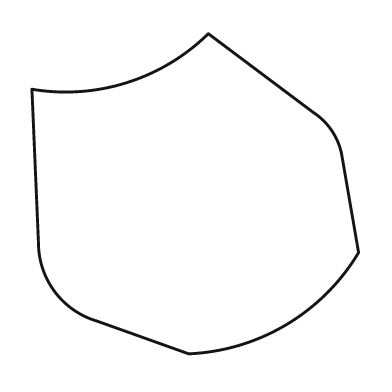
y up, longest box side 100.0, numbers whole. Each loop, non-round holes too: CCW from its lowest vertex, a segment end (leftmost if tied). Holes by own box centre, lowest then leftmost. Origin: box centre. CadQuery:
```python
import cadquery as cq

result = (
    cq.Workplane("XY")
    .moveTo(-2.0, -49.0)
    .threePointArc((28.0, -40.0), (50.0, -18.0))
    .lineTo(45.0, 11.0)
    .threePointArc((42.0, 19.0), (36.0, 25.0))
    .lineTo(4.0, 49.0)
    .threePointArc((-21.0, 34.0), (-50.0, 32.0))
    .lineTo(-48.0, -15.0)
    .threePointArc((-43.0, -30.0), (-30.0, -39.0))
    .close()
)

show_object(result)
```